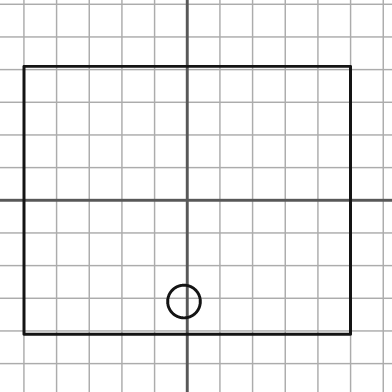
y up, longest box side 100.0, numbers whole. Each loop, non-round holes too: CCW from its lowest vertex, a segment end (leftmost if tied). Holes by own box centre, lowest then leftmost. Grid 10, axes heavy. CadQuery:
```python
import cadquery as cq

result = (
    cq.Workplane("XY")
    .moveTo(-50.0, -41.0)
    .lineTo(50.0, -41.0)
    .lineTo(50.0, 41.0)
    .lineTo(-50.0, 41.0)
    .close()
    .moveTo(-1.0, -31.0)
    .circle(5.0)
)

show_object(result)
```